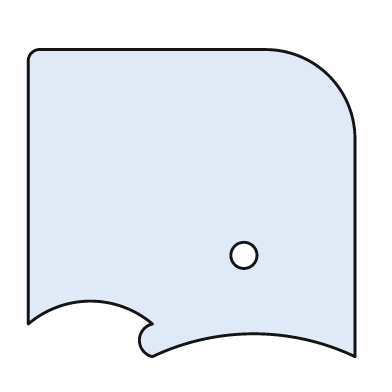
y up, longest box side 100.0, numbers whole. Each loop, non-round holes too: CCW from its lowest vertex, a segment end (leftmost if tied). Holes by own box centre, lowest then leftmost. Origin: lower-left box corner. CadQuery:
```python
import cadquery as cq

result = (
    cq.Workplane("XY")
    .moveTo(38.0, 0.0)
    .threePointArc((69.0, 7.0), (100.0, 0.0))
    .lineTo(100.0, 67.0)
    .threePointArc((92.0, 86.0), (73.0, 94.0))
    .lineTo(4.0, 94.0)
    .threePointArc((1.0, 93.0), (0.0, 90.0))
    .lineTo(0.0, 10.0)
    .threePointArc((19.0, 17.0), (38.0, 10.0))
    .threePointArc((34.0, 5.0), (38.0, 0.0))
    .close()
    .moveTo(66.0, 31.0)
    .circle(4.0)
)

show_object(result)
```